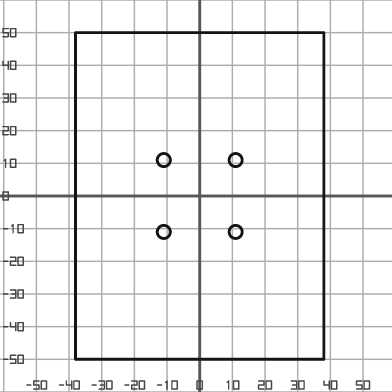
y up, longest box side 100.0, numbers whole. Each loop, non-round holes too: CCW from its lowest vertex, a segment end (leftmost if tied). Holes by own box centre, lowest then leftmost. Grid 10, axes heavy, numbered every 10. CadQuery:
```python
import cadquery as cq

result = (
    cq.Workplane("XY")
    .moveTo(-38.0, -50.0)
    .lineTo(38.0, -50.0)
    .lineTo(38.0, 50.0)
    .lineTo(-38.0, 50.0)
    .close()
    .moveTo(-11.0, -11.0)
    .circle(2.0)
    .moveTo(11.0, -11.0)
    .circle(2.0)
    .moveTo(-11.0, 11.0)
    .circle(2.0)
    .moveTo(11.0, 11.0)
    .circle(2.0)
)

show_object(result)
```